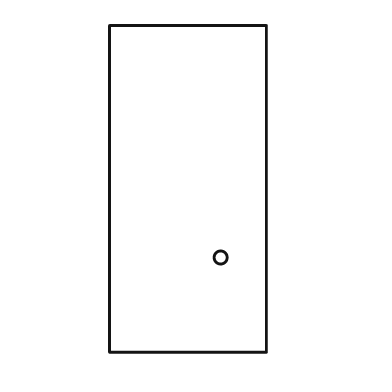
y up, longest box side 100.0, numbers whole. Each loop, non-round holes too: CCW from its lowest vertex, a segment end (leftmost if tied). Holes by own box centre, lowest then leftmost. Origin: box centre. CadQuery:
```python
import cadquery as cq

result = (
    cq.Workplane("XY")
    .moveTo(-24.0, -50.0)
    .lineTo(24.0, -50.0)
    .lineTo(24.0, 50.0)
    .lineTo(-24.0, 50.0)
    .close()
    .moveTo(10.0, -21.0)
    .circle(2.0)
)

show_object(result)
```